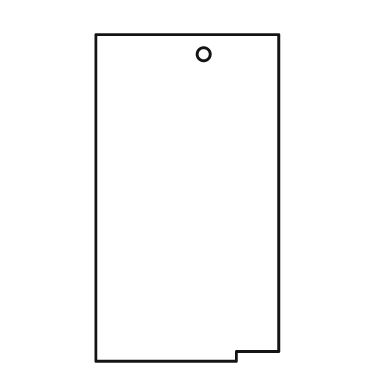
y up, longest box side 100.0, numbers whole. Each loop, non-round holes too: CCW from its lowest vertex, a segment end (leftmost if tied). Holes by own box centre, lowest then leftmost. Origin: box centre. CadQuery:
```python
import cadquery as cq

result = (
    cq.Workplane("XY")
    .moveTo(-28.0, -50.0)
    .lineTo(15.0, -50.0)
    .lineTo(15.0, -47.0)
    .lineTo(28.0, -47.0)
    .lineTo(28.0, 50.0)
    .lineTo(-28.0, 50.0)
    .close()
    .moveTo(5.0, 44.0)
    .circle(2.0)
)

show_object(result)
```